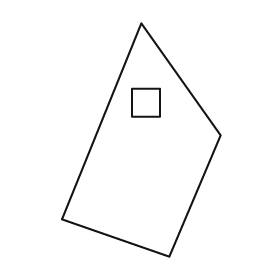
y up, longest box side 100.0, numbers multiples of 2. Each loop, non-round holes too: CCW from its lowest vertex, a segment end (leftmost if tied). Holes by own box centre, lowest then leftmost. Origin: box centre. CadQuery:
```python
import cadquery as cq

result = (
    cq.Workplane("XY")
    .moveTo(12.0, -50.0)
    .lineTo(34.0, 2.0)
    .lineTo(0.0, 50.0)
    .lineTo(-34.0, -34.0)
    .close()
    .moveTo(-4.0, 10.0)
    .lineTo(8.0, 10.0)
    .lineTo(8.0, 22.0)
    .lineTo(-4.0, 22.0)
    .close()
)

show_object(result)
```